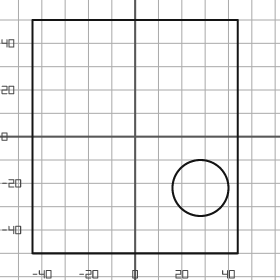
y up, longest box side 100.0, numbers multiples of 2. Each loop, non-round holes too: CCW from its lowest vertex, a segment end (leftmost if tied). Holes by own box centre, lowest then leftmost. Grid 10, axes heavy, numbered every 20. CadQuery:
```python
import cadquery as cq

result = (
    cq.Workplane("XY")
    .moveTo(-44.0, -50.0)
    .lineTo(44.0, -50.0)
    .lineTo(44.0, 50.0)
    .lineTo(-44.0, 50.0)
    .close()
    .moveTo(28.0, -22.0)
    .circle(12.0)
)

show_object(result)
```